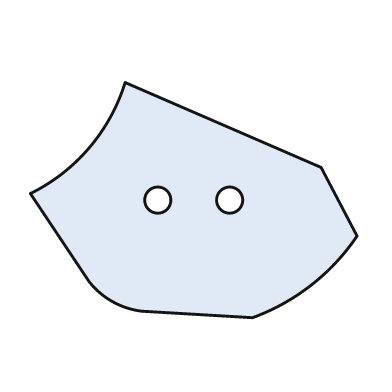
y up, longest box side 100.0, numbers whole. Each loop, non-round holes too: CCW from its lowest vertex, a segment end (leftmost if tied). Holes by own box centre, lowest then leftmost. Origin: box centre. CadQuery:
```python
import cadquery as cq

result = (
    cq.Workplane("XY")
    .moveTo(18.0, -36.0)
    .threePointArc((36.0, -26.0), (50.0, -11.0))
    .lineTo(39.0, 10.0)
    .lineTo(-21.0, 36.0)
    .threePointArc((-32.0, 16.0), (-50.0, 2.0))
    .lineTo(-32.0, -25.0)
    .threePointArc((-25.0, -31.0), (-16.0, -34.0))
    .close()
    .moveTo(-11.0, 0.0)
    .circle(4.0)
    .moveTo(11.0, 0.0)
    .circle(4.0)
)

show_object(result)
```